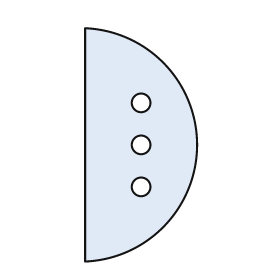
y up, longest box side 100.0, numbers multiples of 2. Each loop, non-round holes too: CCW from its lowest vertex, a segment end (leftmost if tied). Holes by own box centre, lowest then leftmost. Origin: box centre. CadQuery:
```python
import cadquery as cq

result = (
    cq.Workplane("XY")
    .moveTo(-24.0, -50.0)
    .threePointArc((24.0, 0.0), (-24.0, 50.0))
    .close()
    .moveTo(0.0, -18.0)
    .circle(4.0)
    .moveTo(0.0, 0.0)
    .circle(4.0)
    .moveTo(0.0, 18.0)
    .circle(4.0)
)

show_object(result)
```